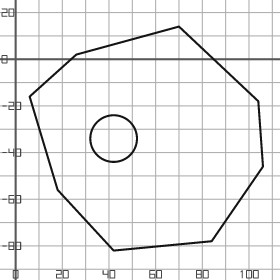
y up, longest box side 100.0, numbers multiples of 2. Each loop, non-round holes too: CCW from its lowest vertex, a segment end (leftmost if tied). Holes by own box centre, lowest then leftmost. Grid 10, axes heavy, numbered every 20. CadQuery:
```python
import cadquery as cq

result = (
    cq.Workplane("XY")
    .moveTo(42.0, -82.0)
    .lineTo(84.0, -78.0)
    .lineTo(106.0, -46.0)
    .lineTo(104.0, -18.0)
    .lineTo(70.0, 14.0)
    .lineTo(26.0, 2.0)
    .lineTo(6.0, -16.0)
    .lineTo(18.0, -56.0)
    .close()
    .moveTo(42.0, -34.0)
    .circle(10.0)
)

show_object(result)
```